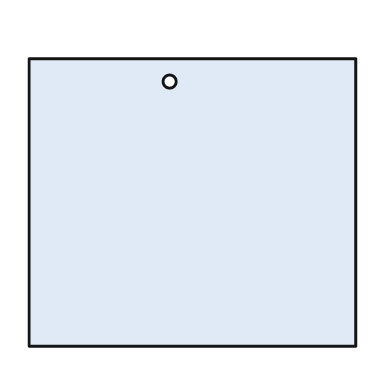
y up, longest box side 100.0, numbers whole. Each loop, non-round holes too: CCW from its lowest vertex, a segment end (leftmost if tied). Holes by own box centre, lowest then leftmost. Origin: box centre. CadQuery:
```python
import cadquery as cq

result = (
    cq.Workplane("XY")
    .moveTo(-50.0, -44.0)
    .lineTo(50.0, -44.0)
    .lineTo(50.0, 44.0)
    .lineTo(-50.0, 44.0)
    .close()
    .moveTo(-7.0, 37.0)
    .circle(2.0)
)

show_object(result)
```